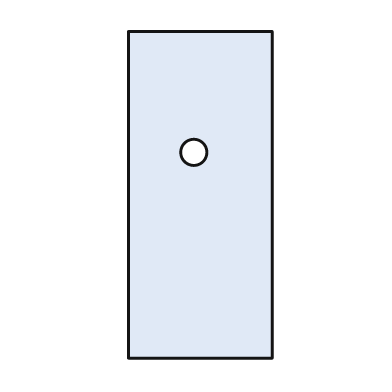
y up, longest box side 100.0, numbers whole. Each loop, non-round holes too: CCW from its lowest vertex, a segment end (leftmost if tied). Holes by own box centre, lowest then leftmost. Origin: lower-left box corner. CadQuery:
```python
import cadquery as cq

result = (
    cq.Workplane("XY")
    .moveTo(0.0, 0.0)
    .lineTo(44.0, 0.0)
    .lineTo(44.0, 100.0)
    .lineTo(0.0, 100.0)
    .close()
    .moveTo(20.0, 63.0)
    .circle(4.0)
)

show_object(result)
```